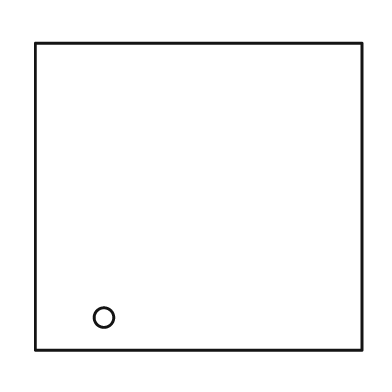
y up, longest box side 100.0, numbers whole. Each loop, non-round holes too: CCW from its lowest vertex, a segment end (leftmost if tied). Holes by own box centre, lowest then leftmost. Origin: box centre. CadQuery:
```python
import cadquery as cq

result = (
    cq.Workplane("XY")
    .moveTo(-50.0, -47.0)
    .lineTo(50.0, -47.0)
    .lineTo(50.0, 47.0)
    .lineTo(-50.0, 47.0)
    .close()
    .moveTo(-29.0, -37.0)
    .circle(3.0)
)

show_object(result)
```